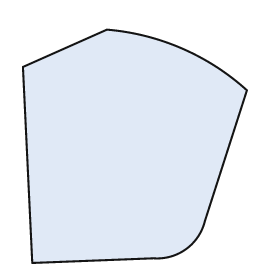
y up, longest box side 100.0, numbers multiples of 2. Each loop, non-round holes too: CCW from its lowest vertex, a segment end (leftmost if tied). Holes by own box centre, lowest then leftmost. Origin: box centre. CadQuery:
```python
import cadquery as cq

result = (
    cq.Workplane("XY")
    .moveTo(-44.0, -50.0)
    .lineTo(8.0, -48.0)
    .threePointArc((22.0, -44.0), (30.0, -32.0))
    .lineTo(48.0, 24.0)
    .threePointArc((20.0, 42.0), (-12.0, 50.0))
    .lineTo(-48.0, 34.0)
    .close()
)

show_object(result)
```